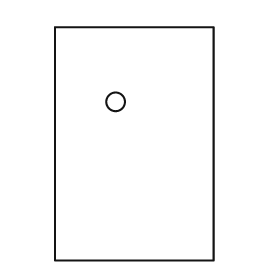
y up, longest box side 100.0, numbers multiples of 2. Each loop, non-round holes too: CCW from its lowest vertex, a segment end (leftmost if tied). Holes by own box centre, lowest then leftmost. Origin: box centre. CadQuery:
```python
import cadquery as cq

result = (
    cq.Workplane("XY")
    .moveTo(-34.0, -50.0)
    .lineTo(34.0, -50.0)
    .lineTo(34.0, 50.0)
    .lineTo(-34.0, 50.0)
    .close()
    .moveTo(-8.0, 18.0)
    .circle(4.0)
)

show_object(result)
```